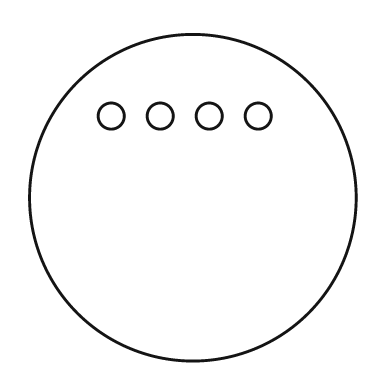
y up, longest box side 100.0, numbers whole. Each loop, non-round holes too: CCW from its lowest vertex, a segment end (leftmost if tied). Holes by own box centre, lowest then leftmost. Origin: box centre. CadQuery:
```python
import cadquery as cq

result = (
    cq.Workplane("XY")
    .moveTo(0.0, 0.0)
    .circle(50.0)
    .moveTo(-25.0, 25.0)
    .circle(4.0)
    .moveTo(-10.0, 25.0)
    .circle(4.0)
    .moveTo(5.0, 25.0)
    .circle(4.0)
    .moveTo(20.0, 25.0)
    .circle(4.0)
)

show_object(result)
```